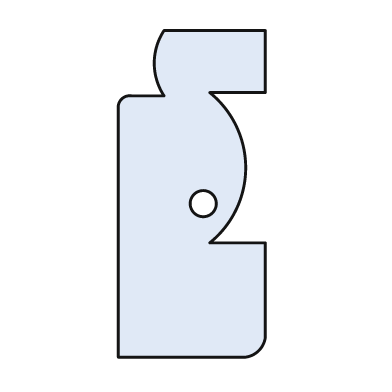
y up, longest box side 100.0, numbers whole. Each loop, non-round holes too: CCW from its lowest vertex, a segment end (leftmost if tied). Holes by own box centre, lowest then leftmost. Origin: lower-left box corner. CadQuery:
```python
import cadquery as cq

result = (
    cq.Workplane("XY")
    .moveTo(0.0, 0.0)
    .lineTo(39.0, 0.0)
    .threePointArc((43.0, 2.0), (45.0, 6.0))
    .lineTo(45.0, 35.0)
    .lineTo(28.0, 35.0)
    .threePointArc((39.0, 58.0), (28.0, 81.0))
    .lineTo(45.0, 81.0)
    .lineTo(45.0, 100.0)
    .lineTo(14.0, 100.0)
    .threePointArc((11.0, 90.0), (14.0, 80.0))
    .lineTo(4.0, 80.0)
    .threePointArc((1.0, 79.0), (0.0, 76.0))
    .close()
    .moveTo(26.0, 47.0)
    .circle(4.0)
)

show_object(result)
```